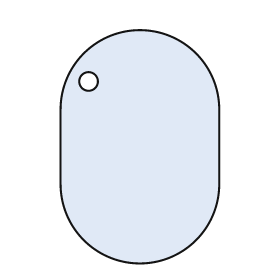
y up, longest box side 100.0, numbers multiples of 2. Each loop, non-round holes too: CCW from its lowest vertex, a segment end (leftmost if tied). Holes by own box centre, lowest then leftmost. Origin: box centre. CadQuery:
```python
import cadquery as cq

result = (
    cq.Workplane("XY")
    .moveTo(-34.0, -16.0)
    .threePointArc((0.0, -50.0), (34.0, -16.0))
    .lineTo(34.0, 16.0)
    .threePointArc((0.0, 50.0), (-34.0, 16.0))
    .close()
    .moveTo(-22.0, 28.0)
    .circle(4.0)
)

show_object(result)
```